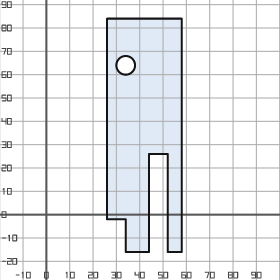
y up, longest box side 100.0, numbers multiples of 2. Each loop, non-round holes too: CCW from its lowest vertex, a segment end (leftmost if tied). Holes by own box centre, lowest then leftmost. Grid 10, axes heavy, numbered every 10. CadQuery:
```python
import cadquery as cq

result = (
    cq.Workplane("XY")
    .moveTo(34.0, -16.0)
    .lineTo(44.0, -16.0)
    .lineTo(44.0, 26.0)
    .lineTo(52.0, 26.0)
    .lineTo(52.0, -16.0)
    .lineTo(58.0, -16.0)
    .lineTo(58.0, 84.0)
    .lineTo(26.0, 84.0)
    .lineTo(26.0, -2.0)
    .lineTo(34.0, -2.0)
    .close()
    .moveTo(34.0, 64.0)
    .circle(4.0)
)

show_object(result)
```